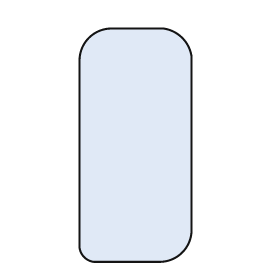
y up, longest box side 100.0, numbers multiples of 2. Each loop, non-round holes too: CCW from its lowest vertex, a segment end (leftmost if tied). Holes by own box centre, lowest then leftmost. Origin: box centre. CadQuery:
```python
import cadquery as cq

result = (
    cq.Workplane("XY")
    .moveTo(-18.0, -50.0)
    .lineTo(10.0, -50.0)
    .threePointArc((20.0, -46.0), (24.0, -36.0))
    .lineTo(24.0, 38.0)
    .threePointArc((20.0, 46.0), (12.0, 50.0))
    .lineTo(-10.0, 50.0)
    .threePointArc((-20.0, 46.0), (-24.0, 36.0))
    .lineTo(-24.0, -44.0)
    .threePointArc((-22.0, -48.0), (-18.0, -50.0))
    .close()
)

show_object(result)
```